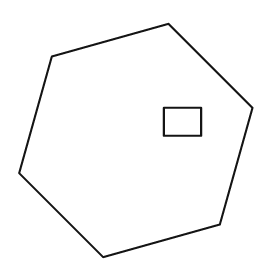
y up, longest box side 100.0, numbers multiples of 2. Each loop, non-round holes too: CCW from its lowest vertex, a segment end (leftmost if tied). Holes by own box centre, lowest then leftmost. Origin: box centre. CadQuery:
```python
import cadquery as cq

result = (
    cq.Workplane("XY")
    .moveTo(-14.0, -50.0)
    .lineTo(36.0, -36.0)
    .lineTo(50.0, 14.0)
    .lineTo(14.0, 50.0)
    .lineTo(-36.0, 36.0)
    .lineTo(-50.0, -14.0)
    .close()
    .moveTo(12.0, 2.0)
    .lineTo(28.0, 2.0)
    .lineTo(28.0, 14.0)
    .lineTo(12.0, 14.0)
    .close()
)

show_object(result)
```